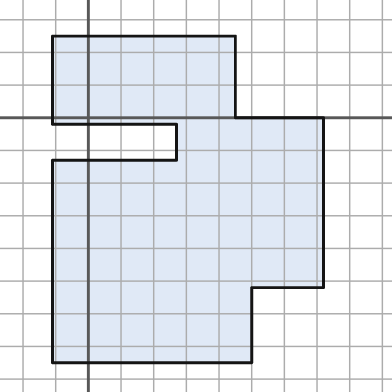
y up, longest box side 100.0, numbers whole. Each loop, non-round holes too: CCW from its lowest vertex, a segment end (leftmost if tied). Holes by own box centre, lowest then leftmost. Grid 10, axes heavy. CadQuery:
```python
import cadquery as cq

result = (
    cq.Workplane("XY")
    .moveTo(-11.0, -75.0)
    .lineTo(50.0, -75.0)
    .lineTo(50.0, -52.0)
    .lineTo(72.0, -52.0)
    .lineTo(72.0, 0.0)
    .lineTo(45.0, 0.0)
    .lineTo(45.0, 25.0)
    .lineTo(-11.0, 25.0)
    .lineTo(-11.0, -2.0)
    .lineTo(27.0, -2.0)
    .lineTo(27.0, -13.0)
    .lineTo(-11.0, -13.0)
    .close()
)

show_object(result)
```